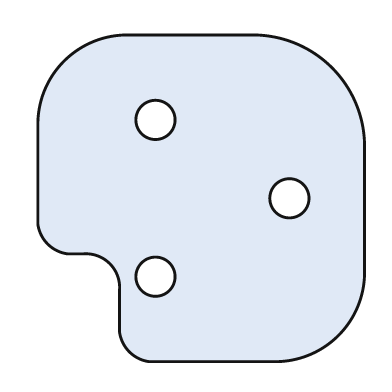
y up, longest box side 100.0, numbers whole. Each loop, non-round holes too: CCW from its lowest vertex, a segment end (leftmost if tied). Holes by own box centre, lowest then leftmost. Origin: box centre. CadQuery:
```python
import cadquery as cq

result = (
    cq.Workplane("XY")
    .moveTo(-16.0, -50.0)
    .lineTo(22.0, -50.0)
    .threePointArc((42.0, -42.0), (50.0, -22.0))
    .lineTo(50.0, 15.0)
    .threePointArc((40.0, 40.0), (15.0, 50.0))
    .lineTo(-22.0, 50.0)
    .threePointArc((-42.0, 42.0), (-50.0, 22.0))
    .lineTo(-50.0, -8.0)
    .threePointArc((-47.0, -14.0), (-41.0, -17.0))
    .lineTo(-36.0, -17.0)
    .threePointArc((-28.0, -20.0), (-25.0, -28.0))
    .lineTo(-25.0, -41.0)
    .threePointArc((-22.0, -47.0), (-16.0, -50.0))
    .close()
    .moveTo(-14.0, -24.0)
    .circle(6.0)
    .moveTo(27.0, 0.0)
    .circle(6.0)
    .moveTo(-14.0, 24.0)
    .circle(6.0)
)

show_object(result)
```